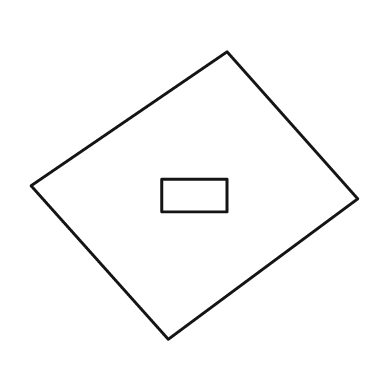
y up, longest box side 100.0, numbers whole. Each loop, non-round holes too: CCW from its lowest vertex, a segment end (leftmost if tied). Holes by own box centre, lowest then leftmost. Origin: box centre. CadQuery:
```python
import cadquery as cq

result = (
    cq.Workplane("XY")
    .moveTo(-8.0, -44.0)
    .lineTo(50.0, -1.0)
    .lineTo(10.0, 44.0)
    .lineTo(-50.0, 3.0)
    .close()
    .moveTo(-10.0, -5.0)
    .lineTo(10.0, -5.0)
    .lineTo(10.0, 5.0)
    .lineTo(-10.0, 5.0)
    .close()
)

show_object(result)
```